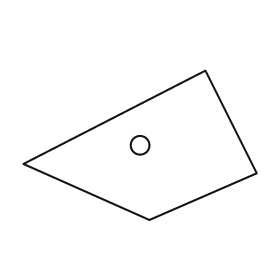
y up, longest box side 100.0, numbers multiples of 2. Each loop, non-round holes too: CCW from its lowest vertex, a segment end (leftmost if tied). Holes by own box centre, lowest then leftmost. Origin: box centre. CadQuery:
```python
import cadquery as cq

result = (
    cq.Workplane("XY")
    .moveTo(4.0, -32.0)
    .lineTo(50.0, -12.0)
    .lineTo(28.0, 32.0)
    .lineTo(-50.0, -8.0)
    .close()
    .moveTo(0.0, 0.0)
    .circle(4.0)
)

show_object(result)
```